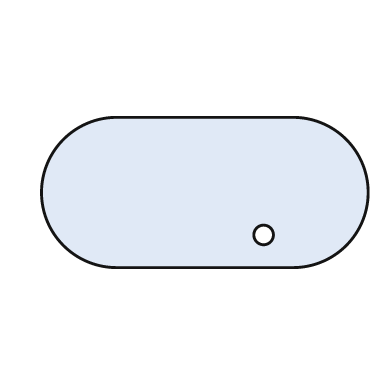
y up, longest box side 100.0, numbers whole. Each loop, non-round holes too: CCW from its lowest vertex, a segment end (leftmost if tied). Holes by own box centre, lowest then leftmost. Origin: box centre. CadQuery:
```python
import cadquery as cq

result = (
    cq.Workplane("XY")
    .moveTo(-27.0, -23.0)
    .lineTo(27.0, -23.0)
    .threePointArc((50.0, 0.0), (27.0, 23.0))
    .lineTo(-27.0, 23.0)
    .threePointArc((-50.0, 0.0), (-27.0, -23.0))
    .close()
    .moveTo(18.0, -13.0)
    .circle(3.0)
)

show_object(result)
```